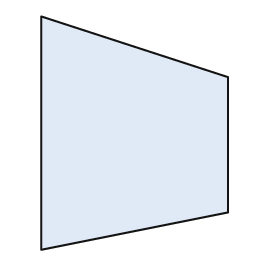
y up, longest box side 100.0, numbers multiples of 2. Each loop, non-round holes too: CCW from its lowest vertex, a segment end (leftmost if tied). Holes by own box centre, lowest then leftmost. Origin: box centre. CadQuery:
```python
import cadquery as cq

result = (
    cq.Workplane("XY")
    .moveTo(-40.0, -50.0)
    .lineTo(40.0, -34.0)
    .lineTo(40.0, 24.0)
    .lineTo(-40.0, 50.0)
    .close()
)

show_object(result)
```